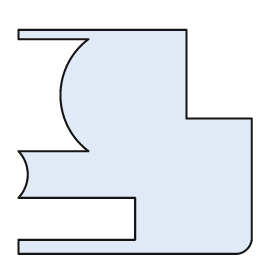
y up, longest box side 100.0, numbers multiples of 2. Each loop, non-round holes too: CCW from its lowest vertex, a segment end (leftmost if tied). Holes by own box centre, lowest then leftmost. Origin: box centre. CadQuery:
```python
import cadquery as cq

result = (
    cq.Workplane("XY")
    .moveTo(-50.0, -48.0)
    .lineTo(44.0, -48.0)
    .threePointArc((48.0, -46.0), (50.0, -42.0))
    .lineTo(50.0, 10.0)
    .lineTo(22.0, 10.0)
    .lineTo(22.0, 48.0)
    .lineTo(-50.0, 48.0)
    .lineTo(-50.0, 44.0)
    .lineTo(-20.0, 44.0)
    .threePointArc((-32.0, 20.0), (-20.0, -4.0))
    .lineTo(-50.0, -4.0)
    .threePointArc((-46.0, -14.0), (-50.0, -24.0))
    .lineTo(0.0, -24.0)
    .lineTo(0.0, -42.0)
    .lineTo(-50.0, -42.0)
    .close()
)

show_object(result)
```